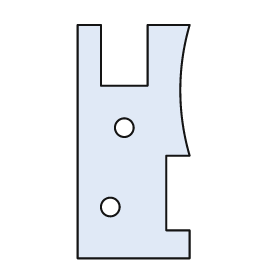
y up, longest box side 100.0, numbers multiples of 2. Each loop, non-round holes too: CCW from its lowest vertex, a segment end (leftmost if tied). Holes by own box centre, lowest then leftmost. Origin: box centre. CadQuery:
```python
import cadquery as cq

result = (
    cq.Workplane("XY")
    .moveTo(-24.0, -50.0)
    .lineTo(24.0, -50.0)
    .lineTo(24.0, -38.0)
    .lineTo(14.0, -38.0)
    .lineTo(14.0, -6.0)
    .lineTo(24.0, -6.0)
    .threePointArc((20.0, 22.0), (24.0, 50.0))
    .lineTo(6.0, 50.0)
    .lineTo(6.0, 24.0)
    .lineTo(-14.0, 24.0)
    .lineTo(-14.0, 50.0)
    .lineTo(-24.0, 50.0)
    .close()
    .moveTo(-10.0, -28.0)
    .circle(4.0)
    .moveTo(-4.0, 6.0)
    .circle(4.0)
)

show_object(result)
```